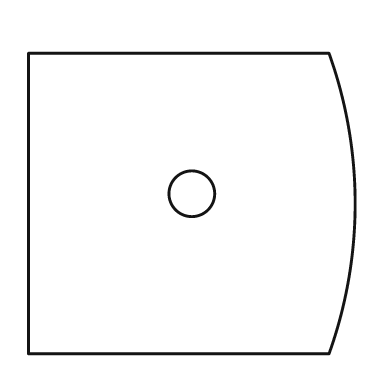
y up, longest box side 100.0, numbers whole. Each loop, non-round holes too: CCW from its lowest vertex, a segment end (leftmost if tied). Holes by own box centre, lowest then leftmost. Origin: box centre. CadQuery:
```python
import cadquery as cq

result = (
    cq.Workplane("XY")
    .moveTo(-50.0, -46.0)
    .lineTo(42.0, -46.0)
    .threePointArc((50.0, 0.0), (42.0, 46.0))
    .lineTo(-50.0, 46.0)
    .close()
    .moveTo(0.0, 3.0)
    .circle(7.0)
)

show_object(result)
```